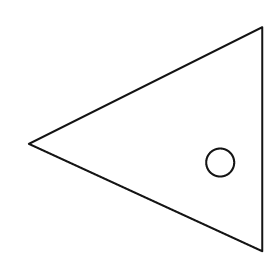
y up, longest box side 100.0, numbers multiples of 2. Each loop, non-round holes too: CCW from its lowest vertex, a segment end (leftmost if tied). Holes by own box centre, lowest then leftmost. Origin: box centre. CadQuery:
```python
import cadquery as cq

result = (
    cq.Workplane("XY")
    .moveTo(50.0, -48.0)
    .lineTo(50.0, 48.0)
    .lineTo(-50.0, -2.0)
    .close()
    .moveTo(32.0, -10.0)
    .circle(6.0)
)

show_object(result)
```